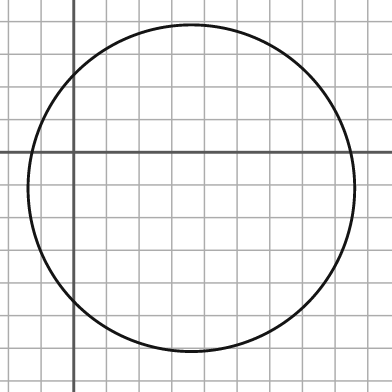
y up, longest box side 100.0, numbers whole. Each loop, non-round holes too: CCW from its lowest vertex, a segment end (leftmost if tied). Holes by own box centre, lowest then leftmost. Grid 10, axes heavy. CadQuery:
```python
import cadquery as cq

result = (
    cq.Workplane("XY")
    .moveTo(36.0, -11.0)
    .circle(50.0)
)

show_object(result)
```